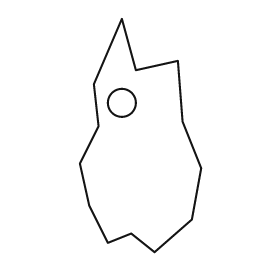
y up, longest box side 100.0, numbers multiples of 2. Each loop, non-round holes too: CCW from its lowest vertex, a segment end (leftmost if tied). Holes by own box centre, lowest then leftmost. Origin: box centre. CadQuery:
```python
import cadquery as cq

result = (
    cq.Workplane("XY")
    .moveTo(6.0, -50.0)
    .lineTo(22.0, -36.0)
    .lineTo(26.0, -14.0)
    .lineTo(18.0, 6.0)
    .lineTo(16.0, 32.0)
    .lineTo(-2.0, 28.0)
    .lineTo(-8.0, 50.0)
    .lineTo(-20.0, 22.0)
    .lineTo(-18.0, 4.0)
    .lineTo(-26.0, -12.0)
    .lineTo(-22.0, -30.0)
    .lineTo(-14.0, -46.0)
    .lineTo(-4.0, -42.0)
    .close()
    .moveTo(-8.0, 14.0)
    .circle(6.0)
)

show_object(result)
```